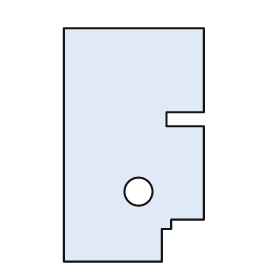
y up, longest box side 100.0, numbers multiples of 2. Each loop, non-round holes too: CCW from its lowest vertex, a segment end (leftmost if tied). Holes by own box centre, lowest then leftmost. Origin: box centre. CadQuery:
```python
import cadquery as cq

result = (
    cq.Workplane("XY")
    .moveTo(-30.0, -50.0)
    .lineTo(12.0, -50.0)
    .lineTo(12.0, -36.0)
    .lineTo(16.0, -36.0)
    .lineTo(16.0, -32.0)
    .lineTo(30.0, -32.0)
    .lineTo(30.0, 8.0)
    .lineTo(14.0, 8.0)
    .lineTo(14.0, 14.0)
    .lineTo(30.0, 14.0)
    .lineTo(30.0, 50.0)
    .lineTo(-30.0, 50.0)
    .close()
    .moveTo(2.0, -20.0)
    .circle(6.0)
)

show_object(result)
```